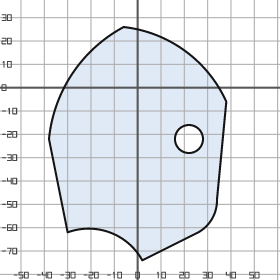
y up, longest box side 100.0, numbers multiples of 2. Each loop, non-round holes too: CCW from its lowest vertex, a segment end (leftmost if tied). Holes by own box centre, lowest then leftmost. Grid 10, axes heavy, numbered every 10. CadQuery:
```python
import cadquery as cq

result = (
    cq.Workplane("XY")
    .moveTo(2.0, -74.0)
    .lineTo(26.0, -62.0)
    .threePointArc((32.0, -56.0), (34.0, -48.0))
    .lineTo(38.0, -6.0)
    .threePointArc((20.0, 16.0), (-6.0, 26.0))
    .threePointArc((-28.0, 6.0), (-38.0, -22.0))
    .lineTo(-30.0, -62.0)
    .threePointArc((-12.0, -62.0), (2.0, -74.0))
    .close()
    .moveTo(22.0, -22.0)
    .circle(6.0)
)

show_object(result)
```